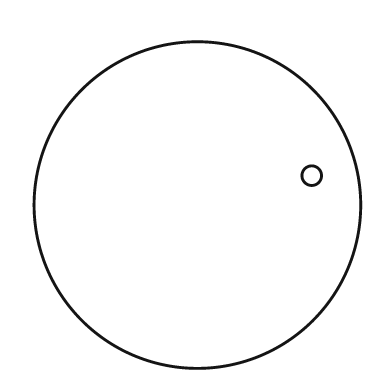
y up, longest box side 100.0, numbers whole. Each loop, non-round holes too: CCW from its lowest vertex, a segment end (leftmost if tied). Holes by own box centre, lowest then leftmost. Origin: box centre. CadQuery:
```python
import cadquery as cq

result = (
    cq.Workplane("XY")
    .moveTo(0.0, 0.0)
    .circle(50.0)
    .moveTo(35.0, 9.0)
    .circle(3.0)
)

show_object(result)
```